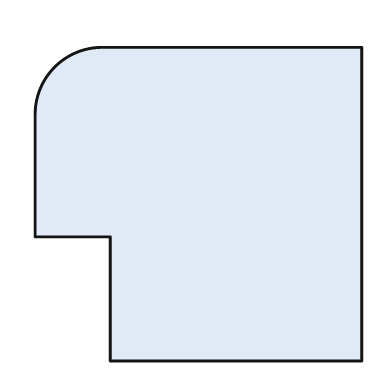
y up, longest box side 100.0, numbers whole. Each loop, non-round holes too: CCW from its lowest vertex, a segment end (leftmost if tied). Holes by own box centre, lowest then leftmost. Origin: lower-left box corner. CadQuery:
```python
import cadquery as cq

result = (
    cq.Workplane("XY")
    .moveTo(23.0, 0.0)
    .lineTo(100.0, 0.0)
    .lineTo(100.0, 96.0)
    .lineTo(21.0, 96.0)
    .threePointArc((6.0, 90.0), (0.0, 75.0))
    .lineTo(0.0, 38.0)
    .lineTo(23.0, 38.0)
    .close()
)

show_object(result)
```